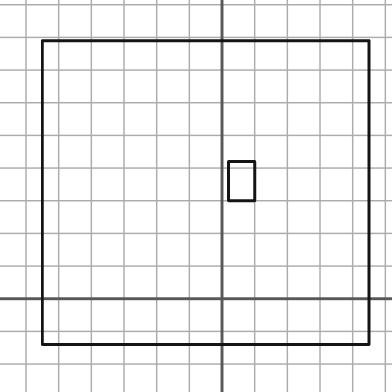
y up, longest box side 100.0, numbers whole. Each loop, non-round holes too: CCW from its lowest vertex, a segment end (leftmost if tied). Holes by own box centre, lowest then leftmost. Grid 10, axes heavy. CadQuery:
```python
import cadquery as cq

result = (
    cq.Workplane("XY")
    .moveTo(-55.0, -14.0)
    .lineTo(45.0, -14.0)
    .lineTo(45.0, 79.0)
    .lineTo(-55.0, 79.0)
    .close()
    .moveTo(2.0, 30.0)
    .lineTo(10.0, 30.0)
    .lineTo(10.0, 42.0)
    .lineTo(2.0, 42.0)
    .close()
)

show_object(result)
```